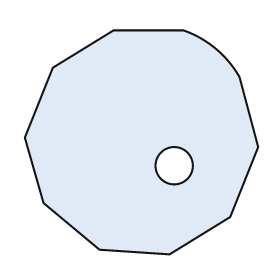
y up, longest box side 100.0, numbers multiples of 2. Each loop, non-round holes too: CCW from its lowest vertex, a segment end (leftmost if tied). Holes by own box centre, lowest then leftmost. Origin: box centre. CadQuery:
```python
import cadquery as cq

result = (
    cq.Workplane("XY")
    .moveTo(12.0, -48.0)
    .lineTo(38.0, -32.0)
    .lineTo(50.0, -2.0)
    .lineTo(42.0, 28.0)
    .threePointArc((32.0, 40.0), (18.0, 48.0))
    .lineTo(-12.0, 48.0)
    .lineTo(-38.0, 32.0)
    .lineTo(-50.0, 2.0)
    .lineTo(-42.0, -26.0)
    .lineTo(-18.0, -46.0)
    .close()
    .moveTo(14.0, -10.0)
    .circle(8.0)
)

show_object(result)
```